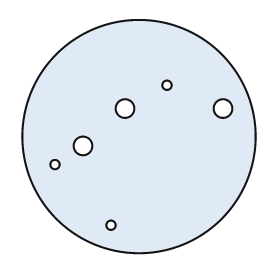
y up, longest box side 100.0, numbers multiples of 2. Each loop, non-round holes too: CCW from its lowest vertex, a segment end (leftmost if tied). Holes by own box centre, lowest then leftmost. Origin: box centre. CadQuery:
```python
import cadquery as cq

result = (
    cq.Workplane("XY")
    .moveTo(0.0, 0.0)
    .circle(50.0)
    .moveTo(-12.0, -38.0)
    .circle(2.0)
    .moveTo(-36.0, -12.0)
    .circle(2.0)
    .moveTo(-24.0, -4.0)
    .circle(4.0)
    .moveTo(-6.0, 12.0)
    .circle(4.0)
    .moveTo(36.0, 12.0)
    .circle(4.0)
    .moveTo(12.0, 22.0)
    .circle(2.0)
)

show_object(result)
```